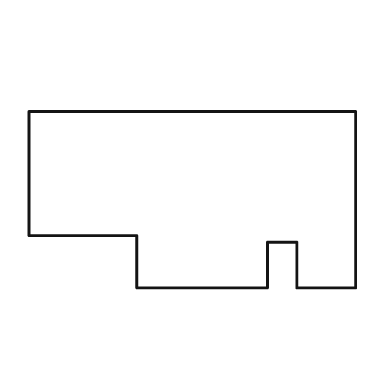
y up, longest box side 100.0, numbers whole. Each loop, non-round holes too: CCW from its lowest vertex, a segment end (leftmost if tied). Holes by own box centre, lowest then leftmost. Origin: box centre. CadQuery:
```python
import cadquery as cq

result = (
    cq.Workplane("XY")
    .moveTo(-17.0, -27.0)
    .lineTo(23.0, -27.0)
    .lineTo(23.0, -13.0)
    .lineTo(32.0, -13.0)
    .lineTo(32.0, -27.0)
    .lineTo(50.0, -27.0)
    .lineTo(50.0, 27.0)
    .lineTo(-50.0, 27.0)
    .lineTo(-50.0, -11.0)
    .lineTo(-17.0, -11.0)
    .close()
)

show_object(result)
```